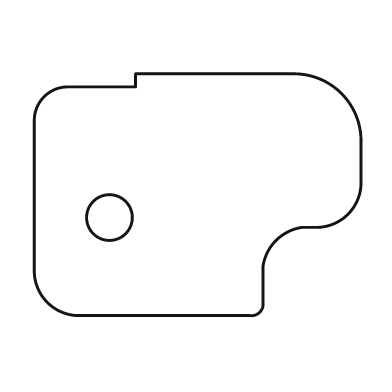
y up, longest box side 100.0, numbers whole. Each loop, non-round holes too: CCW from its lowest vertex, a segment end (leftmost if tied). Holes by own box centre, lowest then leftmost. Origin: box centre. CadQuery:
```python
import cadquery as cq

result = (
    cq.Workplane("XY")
    .moveTo(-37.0, -37.0)
    .lineTo(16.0, -37.0)
    .threePointArc((19.0, -36.0), (20.0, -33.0))
    .lineTo(20.0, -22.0)
    .threePointArc((24.0, -14.0), (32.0, -10.0))
    .lineTo(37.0, -10.0)
    .threePointArc((46.0, -6.0), (50.0, 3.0))
    .lineTo(50.0, 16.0)
    .threePointArc((44.0, 31.0), (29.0, 37.0))
    .lineTo(-19.0, 37.0)
    .lineTo(-19.0, 33.0)
    .lineTo(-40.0, 33.0)
    .threePointArc((-47.0, 30.0), (-50.0, 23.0))
    .lineTo(-50.0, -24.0)
    .threePointArc((-46.0, -33.0), (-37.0, -37.0))
    .close()
    .moveTo(-27.0, -7.0)
    .circle(7.0)
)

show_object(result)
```